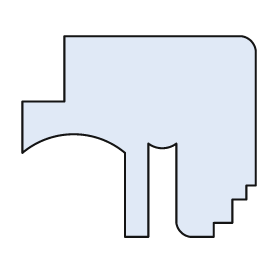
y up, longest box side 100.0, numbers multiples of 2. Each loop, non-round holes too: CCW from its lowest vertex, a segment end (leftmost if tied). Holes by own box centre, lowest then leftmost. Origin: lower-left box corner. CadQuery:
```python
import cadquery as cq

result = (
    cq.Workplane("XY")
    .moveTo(44.0, 0.0)
    .lineTo(54.0, 0.0)
    .lineTo(54.0, 40.0)
    .threePointArc((60.0, 38.0), (66.0, 40.0))
    .lineTo(66.0, 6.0)
    .threePointArc((68.0, 2.0), (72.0, 0.0))
    .lineTo(82.0, 0.0)
    .lineTo(82.0, 6.0)
    .lineTo(90.0, 6.0)
    .lineTo(90.0, 16.0)
    .lineTo(96.0, 16.0)
    .lineTo(96.0, 22.0)
    .lineTo(100.0, 22.0)
    .lineTo(100.0, 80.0)
    .threePointArc((98.0, 84.0), (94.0, 86.0))
    .lineTo(18.0, 86.0)
    .lineTo(18.0, 58.0)
    .lineTo(0.0, 58.0)
    .lineTo(0.0, 36.0)
    .threePointArc((22.0, 44.0), (44.0, 36.0))
    .close()
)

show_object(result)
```